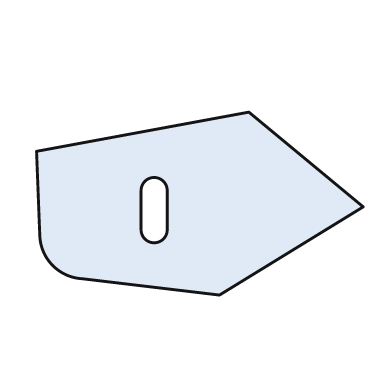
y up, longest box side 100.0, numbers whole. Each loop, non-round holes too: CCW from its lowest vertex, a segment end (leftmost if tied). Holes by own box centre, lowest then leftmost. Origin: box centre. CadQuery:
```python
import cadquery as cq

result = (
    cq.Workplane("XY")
    .moveTo(6.0, -28.0)
    .lineTo(50.0, -1.0)
    .lineTo(15.0, 28.0)
    .lineTo(-50.0, 16.0)
    .lineTo(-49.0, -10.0)
    .threePointArc((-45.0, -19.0), (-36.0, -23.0))
    .close()
    .moveTo(-18.0, -8.0)
    .threePointArc((-14.0, -12.0), (-10.0, -8.0))
    .lineTo(-10.0, 4.0)
    .threePointArc((-14.0, 8.0), (-18.0, 4.0))
    .close()
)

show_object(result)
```